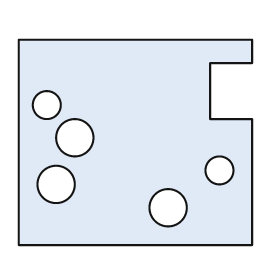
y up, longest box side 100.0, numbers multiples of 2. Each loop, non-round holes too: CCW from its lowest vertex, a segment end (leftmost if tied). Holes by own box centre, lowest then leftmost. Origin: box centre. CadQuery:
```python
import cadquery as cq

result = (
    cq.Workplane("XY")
    .moveTo(-50.0, -44.0)
    .lineTo(50.0, -44.0)
    .lineTo(50.0, 10.0)
    .lineTo(32.0, 10.0)
    .lineTo(32.0, 34.0)
    .lineTo(50.0, 34.0)
    .lineTo(50.0, 44.0)
    .lineTo(-50.0, 44.0)
    .close()
    .moveTo(14.0, -28.0)
    .circle(8.0)
    .moveTo(-34.0, -18.0)
    .circle(8.0)
    .moveTo(36.0, -12.0)
    .circle(6.0)
    .moveTo(-26.0, 2.0)
    .circle(8.0)
    .moveTo(-38.0, 16.0)
    .circle(6.0)
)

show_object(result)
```